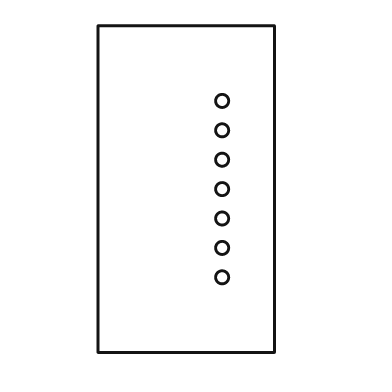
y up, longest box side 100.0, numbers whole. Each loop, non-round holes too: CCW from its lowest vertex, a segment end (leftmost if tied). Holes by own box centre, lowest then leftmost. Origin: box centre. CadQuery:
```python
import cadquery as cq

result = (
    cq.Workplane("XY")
    .moveTo(-27.0, -50.0)
    .lineTo(27.0, -50.0)
    .lineTo(27.0, 50.0)
    .lineTo(-27.0, 50.0)
    .close()
    .moveTo(11.0, -27.0)
    .circle(2.0)
    .moveTo(11.0, -18.0)
    .circle(2.0)
    .moveTo(11.0, -9.0)
    .circle(2.0)
    .moveTo(11.0, 0.0)
    .circle(2.0)
    .moveTo(11.0, 9.0)
    .circle(2.0)
    .moveTo(11.0, 18.0)
    .circle(2.0)
    .moveTo(11.0, 27.0)
    .circle(2.0)
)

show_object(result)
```